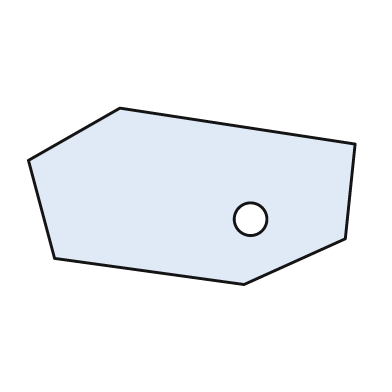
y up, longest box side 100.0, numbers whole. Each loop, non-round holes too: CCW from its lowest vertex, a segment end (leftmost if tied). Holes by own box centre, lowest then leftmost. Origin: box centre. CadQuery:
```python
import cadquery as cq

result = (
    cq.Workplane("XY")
    .moveTo(16.0, -27.0)
    .lineTo(47.0, -13.0)
    .lineTo(50.0, 16.0)
    .lineTo(-22.0, 27.0)
    .lineTo(-50.0, 11.0)
    .lineTo(-42.0, -19.0)
    .close()
    .moveTo(18.0, -7.0)
    .circle(5.0)
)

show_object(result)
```